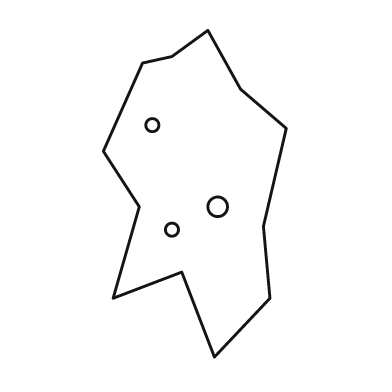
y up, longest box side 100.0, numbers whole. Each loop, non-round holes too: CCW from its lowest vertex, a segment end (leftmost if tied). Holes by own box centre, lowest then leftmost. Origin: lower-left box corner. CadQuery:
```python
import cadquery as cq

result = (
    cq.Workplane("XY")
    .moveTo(34.0, 0.0)
    .lineTo(51.0, 18.0)
    .lineTo(49.0, 40.0)
    .lineTo(56.0, 70.0)
    .lineTo(42.0, 82.0)
    .lineTo(32.0, 100.0)
    .lineTo(21.0, 92.0)
    .lineTo(12.0, 90.0)
    .lineTo(0.0, 63.0)
    .lineTo(11.0, 46.0)
    .lineTo(3.0, 18.0)
    .lineTo(24.0, 26.0)
    .close()
    .moveTo(21.0, 39.0)
    .circle(2.0)
    .moveTo(35.0, 46.0)
    .circle(3.0)
    .moveTo(15.0, 71.0)
    .circle(2.0)
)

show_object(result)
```